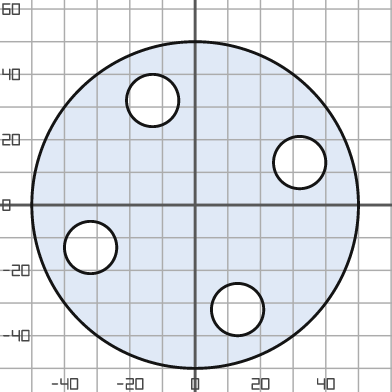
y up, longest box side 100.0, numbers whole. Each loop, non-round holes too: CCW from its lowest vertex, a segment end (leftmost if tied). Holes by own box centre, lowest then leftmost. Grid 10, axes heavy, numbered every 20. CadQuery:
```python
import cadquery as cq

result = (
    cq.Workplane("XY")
    .moveTo(0.0, 0.0)
    .circle(50.0)
    .moveTo(13.0, -32.0)
    .circle(8.0)
    .moveTo(-32.0, -13.0)
    .circle(8.0)
    .moveTo(32.0, 13.0)
    .circle(8.0)
    .moveTo(-13.0, 32.0)
    .circle(8.0)
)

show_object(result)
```